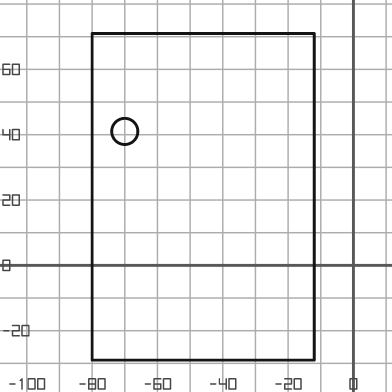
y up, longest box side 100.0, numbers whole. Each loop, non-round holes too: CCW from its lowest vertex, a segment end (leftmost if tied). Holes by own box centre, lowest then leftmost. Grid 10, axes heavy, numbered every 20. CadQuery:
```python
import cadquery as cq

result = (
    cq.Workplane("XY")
    .moveTo(-80.0, -29.0)
    .lineTo(-12.0, -29.0)
    .lineTo(-12.0, 71.0)
    .lineTo(-80.0, 71.0)
    .close()
    .moveTo(-70.0, 41.0)
    .circle(4.0)
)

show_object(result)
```